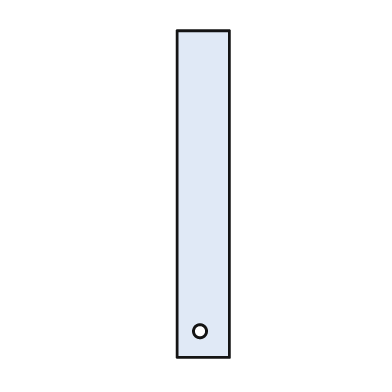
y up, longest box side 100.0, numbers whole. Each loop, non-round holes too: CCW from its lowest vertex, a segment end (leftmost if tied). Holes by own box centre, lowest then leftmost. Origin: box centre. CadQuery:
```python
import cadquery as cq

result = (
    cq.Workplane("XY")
    .moveTo(-8.0, -50.0)
    .lineTo(8.0, -50.0)
    .lineTo(8.0, 50.0)
    .lineTo(-8.0, 50.0)
    .close()
    .moveTo(-1.0, -42.0)
    .circle(2.0)
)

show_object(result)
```